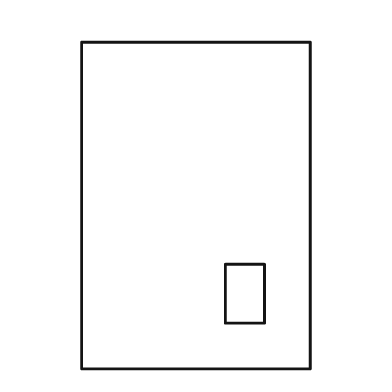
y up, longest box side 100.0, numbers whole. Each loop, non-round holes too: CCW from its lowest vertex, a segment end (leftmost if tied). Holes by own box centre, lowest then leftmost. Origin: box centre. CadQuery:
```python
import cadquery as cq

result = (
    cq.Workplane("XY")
    .moveTo(-35.0, -50.0)
    .lineTo(35.0, -50.0)
    .lineTo(35.0, 50.0)
    .lineTo(-35.0, 50.0)
    .close()
    .moveTo(9.0, -36.0)
    .lineTo(21.0, -36.0)
    .lineTo(21.0, -18.0)
    .lineTo(9.0, -18.0)
    .close()
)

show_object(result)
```